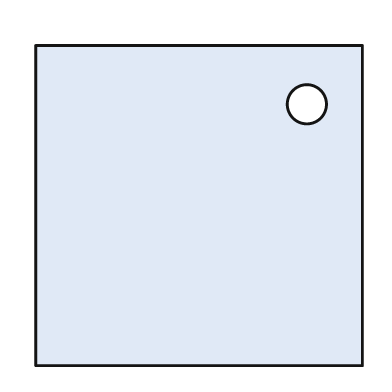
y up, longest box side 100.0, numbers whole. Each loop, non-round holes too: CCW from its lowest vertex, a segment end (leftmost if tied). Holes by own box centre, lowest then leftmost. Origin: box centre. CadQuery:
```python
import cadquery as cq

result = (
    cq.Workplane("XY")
    .moveTo(-50.0, -49.0)
    .lineTo(50.0, -49.0)
    .lineTo(50.0, 49.0)
    .lineTo(-50.0, 49.0)
    .close()
    .moveTo(33.0, 31.0)
    .circle(6.0)
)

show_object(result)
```